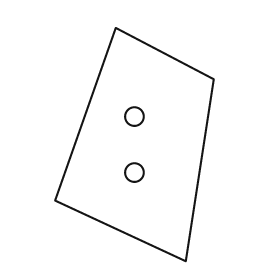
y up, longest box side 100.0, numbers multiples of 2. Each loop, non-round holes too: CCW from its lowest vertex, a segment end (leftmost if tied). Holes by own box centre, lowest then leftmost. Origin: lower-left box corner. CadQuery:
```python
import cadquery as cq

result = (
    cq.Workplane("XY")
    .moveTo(56.0, 0.0)
    .lineTo(68.0, 78.0)
    .lineTo(26.0, 100.0)
    .lineTo(0.0, 26.0)
    .close()
    .moveTo(34.0, 38.0)
    .circle(4.0)
    .moveTo(34.0, 62.0)
    .circle(4.0)
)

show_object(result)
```